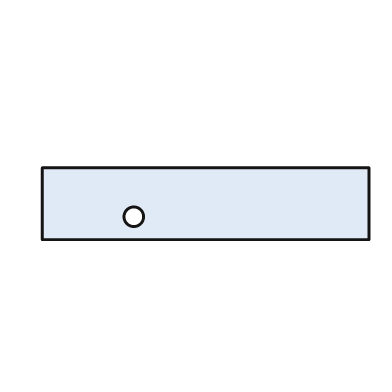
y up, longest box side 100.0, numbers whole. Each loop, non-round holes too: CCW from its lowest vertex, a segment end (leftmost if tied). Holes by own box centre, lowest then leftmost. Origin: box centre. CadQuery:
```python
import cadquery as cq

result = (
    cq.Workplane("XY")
    .moveTo(-50.0, -11.0)
    .lineTo(50.0, -11.0)
    .lineTo(50.0, 11.0)
    .lineTo(-50.0, 11.0)
    .close()
    .moveTo(-22.0, -4.0)
    .circle(3.0)
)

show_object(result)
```